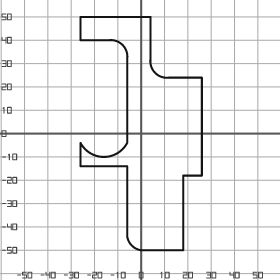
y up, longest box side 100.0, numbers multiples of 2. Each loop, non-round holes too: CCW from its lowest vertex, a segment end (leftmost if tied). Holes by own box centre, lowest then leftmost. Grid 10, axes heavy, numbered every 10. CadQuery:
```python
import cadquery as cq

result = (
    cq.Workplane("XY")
    .moveTo(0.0, -50.0)
    .lineTo(18.0, -50.0)
    .lineTo(18.0, -18.0)
    .lineTo(26.0, -18.0)
    .lineTo(26.0, 24.0)
    .lineTo(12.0, 24.0)
    .threePointArc((6.0, 26.0), (4.0, 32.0))
    .lineTo(4.0, 50.0)
    .lineTo(-26.0, 50.0)
    .lineTo(-26.0, 40.0)
    .lineTo(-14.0, 40.0)
    .threePointArc((-8.0, 38.0), (-6.0, 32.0))
    .lineTo(-6.0, -4.0)
    .threePointArc((-16.0, -10.0), (-26.0, -4.0))
    .lineTo(-26.0, -14.0)
    .lineTo(-6.0, -14.0)
    .lineTo(-6.0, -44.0)
    .threePointArc((-4.0, -48.0), (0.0, -50.0))
    .close()
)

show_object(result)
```